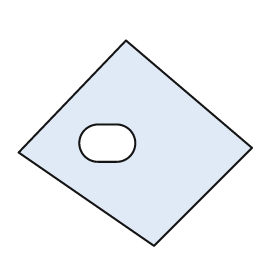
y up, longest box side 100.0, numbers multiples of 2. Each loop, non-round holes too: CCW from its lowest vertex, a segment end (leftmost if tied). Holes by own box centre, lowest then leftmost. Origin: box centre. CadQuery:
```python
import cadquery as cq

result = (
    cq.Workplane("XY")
    .moveTo(8.0, -44.0)
    .lineTo(50.0, -2.0)
    .lineTo(-4.0, 44.0)
    .lineTo(-50.0, -4.0)
    .close()
    .moveTo(-16.0, -8.0)
    .lineTo(-8.0, -8.0)
    .threePointArc((0.0, 0.0), (-8.0, 8.0))
    .lineTo(-16.0, 8.0)
    .threePointArc((-24.0, 0.0), (-16.0, -8.0))
    .close()
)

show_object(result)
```